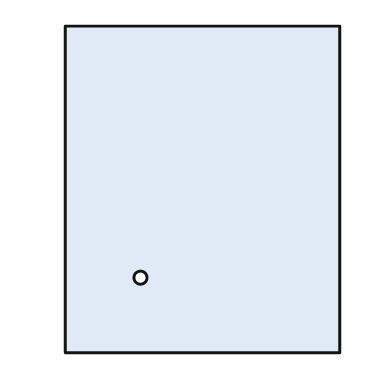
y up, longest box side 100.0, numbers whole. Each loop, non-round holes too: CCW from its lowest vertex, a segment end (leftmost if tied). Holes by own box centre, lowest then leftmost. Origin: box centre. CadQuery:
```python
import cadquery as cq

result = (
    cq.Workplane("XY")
    .moveTo(-42.0, -50.0)
    .lineTo(42.0, -50.0)
    .lineTo(42.0, 50.0)
    .lineTo(-42.0, 50.0)
    .close()
    .moveTo(-19.0, -27.0)
    .circle(2.0)
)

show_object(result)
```